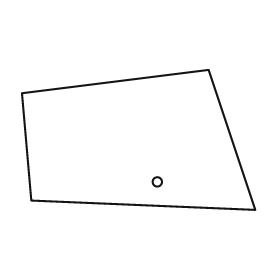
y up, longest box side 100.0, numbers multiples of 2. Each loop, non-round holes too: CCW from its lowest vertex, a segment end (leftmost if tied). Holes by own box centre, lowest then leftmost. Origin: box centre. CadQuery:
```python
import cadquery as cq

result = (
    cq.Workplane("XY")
    .moveTo(50.0, -30.0)
    .lineTo(30.0, 30.0)
    .lineTo(-50.0, 20.0)
    .lineTo(-46.0, -26.0)
    .close()
    .moveTo(8.0, -18.0)
    .circle(2.0)
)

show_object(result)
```